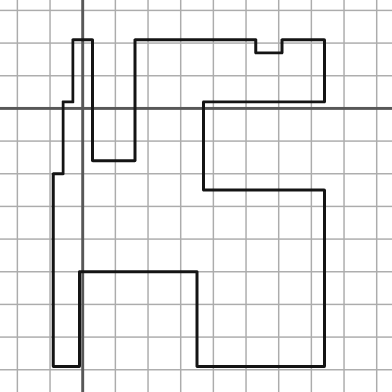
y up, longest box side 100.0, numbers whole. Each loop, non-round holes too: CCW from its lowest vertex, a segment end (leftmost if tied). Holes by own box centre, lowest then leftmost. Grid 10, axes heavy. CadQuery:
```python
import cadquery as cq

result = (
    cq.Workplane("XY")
    .moveTo(-9.0, -79.0)
    .lineTo(-1.0, -79.0)
    .lineTo(-1.0, -50.0)
    .lineTo(35.0, -50.0)
    .lineTo(35.0, -79.0)
    .lineTo(74.0, -79.0)
    .lineTo(74.0, -25.0)
    .lineTo(37.0, -25.0)
    .lineTo(37.0, 2.0)
    .lineTo(74.0, 2.0)
    .lineTo(74.0, 21.0)
    .lineTo(61.0, 21.0)
    .lineTo(61.0, 17.0)
    .lineTo(53.0, 17.0)
    .lineTo(53.0, 21.0)
    .lineTo(16.0, 21.0)
    .lineTo(16.0, -16.0)
    .lineTo(3.0, -16.0)
    .lineTo(3.0, 21.0)
    .lineTo(-3.0, 21.0)
    .lineTo(-3.0, 2.0)
    .lineTo(-6.0, 2.0)
    .lineTo(-6.0, -20.0)
    .lineTo(-9.0, -20.0)
    .close()
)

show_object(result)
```